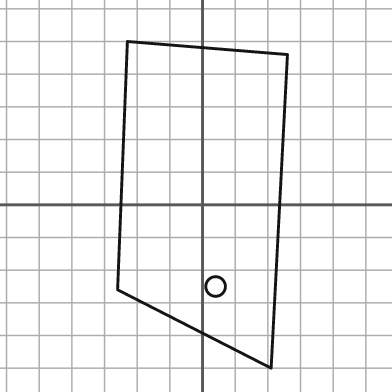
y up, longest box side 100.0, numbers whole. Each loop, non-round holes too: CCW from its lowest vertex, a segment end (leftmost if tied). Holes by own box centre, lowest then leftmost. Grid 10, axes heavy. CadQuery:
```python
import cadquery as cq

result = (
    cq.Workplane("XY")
    .moveTo(21.0, -50.0)
    .lineTo(26.0, 46.0)
    .lineTo(-23.0, 50.0)
    .lineTo(-26.0, -26.0)
    .close()
    .moveTo(4.0, -25.0)
    .circle(3.0)
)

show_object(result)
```